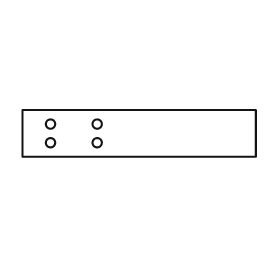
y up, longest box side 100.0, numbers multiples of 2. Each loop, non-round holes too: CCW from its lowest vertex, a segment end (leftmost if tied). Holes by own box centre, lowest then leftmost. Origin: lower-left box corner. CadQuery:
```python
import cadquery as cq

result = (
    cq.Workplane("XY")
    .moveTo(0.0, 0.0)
    .lineTo(100.0, 0.0)
    .lineTo(100.0, 20.0)
    .lineTo(0.0, 20.0)
    .close()
    .moveTo(12.0, 6.0)
    .circle(2.0)
    .moveTo(32.0, 6.0)
    .circle(2.0)
    .moveTo(12.0, 14.0)
    .circle(2.0)
    .moveTo(32.0, 14.0)
    .circle(2.0)
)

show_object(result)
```